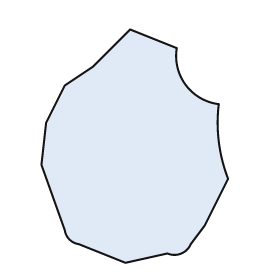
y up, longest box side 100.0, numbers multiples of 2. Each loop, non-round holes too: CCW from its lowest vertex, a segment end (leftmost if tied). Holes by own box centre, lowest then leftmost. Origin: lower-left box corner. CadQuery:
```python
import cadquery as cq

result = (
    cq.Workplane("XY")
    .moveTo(36.0, 0.0)
    .lineTo(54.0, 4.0)
    .threePointArc((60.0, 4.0), (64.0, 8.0))
    .lineTo(70.0, 16.0)
    .lineTo(80.0, 36.0)
    .threePointArc((76.0, 52.0), (76.0, 68.0))
    .threePointArc((62.0, 76.0), (58.0, 92.0))
    .lineTo(38.0, 100.0)
    .lineTo(22.0, 84.0)
    .lineTo(10.0, 76.0)
    .lineTo(2.0, 60.0)
    .lineTo(0.0, 42.0)
    .lineTo(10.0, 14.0)
    .threePointArc((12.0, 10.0), (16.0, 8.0))
    .close()
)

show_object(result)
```